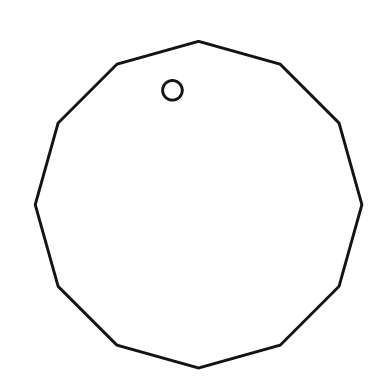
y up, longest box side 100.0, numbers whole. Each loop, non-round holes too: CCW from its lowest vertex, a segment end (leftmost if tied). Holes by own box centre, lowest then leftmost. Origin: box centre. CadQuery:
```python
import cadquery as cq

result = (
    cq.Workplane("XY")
    .moveTo(0.0, -50.0)
    .lineTo(25.0, -43.0)
    .lineTo(43.0, -25.0)
    .lineTo(50.0, 0.0)
    .lineTo(43.0, 25.0)
    .lineTo(25.0, 43.0)
    .lineTo(0.0, 50.0)
    .lineTo(-25.0, 43.0)
    .lineTo(-43.0, 25.0)
    .lineTo(-50.0, 0.0)
    .lineTo(-43.0, -25.0)
    .lineTo(-25.0, -43.0)
    .close()
    .moveTo(-8.0, 35.0)
    .circle(3.0)
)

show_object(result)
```